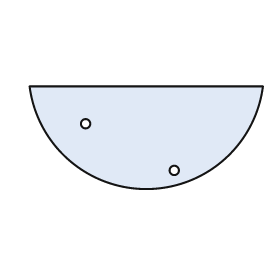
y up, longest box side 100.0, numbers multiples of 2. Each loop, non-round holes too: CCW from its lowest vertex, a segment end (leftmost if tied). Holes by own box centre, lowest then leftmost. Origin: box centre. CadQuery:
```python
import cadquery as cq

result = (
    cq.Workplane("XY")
    .moveTo(-50.0, 22.0)
    .threePointArc((0.0, -22.0), (50.0, 22.0))
    .close()
    .moveTo(12.0, -14.0)
    .circle(2.0)
    .moveTo(-26.0, 6.0)
    .circle(2.0)
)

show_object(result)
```